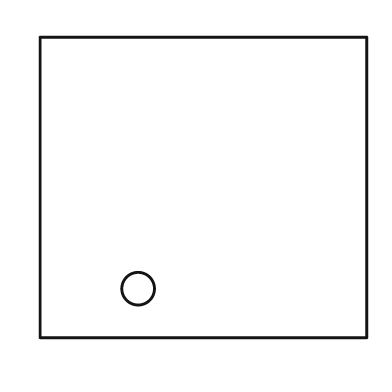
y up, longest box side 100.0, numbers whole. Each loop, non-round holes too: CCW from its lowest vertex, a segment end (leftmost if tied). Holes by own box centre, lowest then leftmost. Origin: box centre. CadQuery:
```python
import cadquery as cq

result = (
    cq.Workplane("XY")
    .moveTo(-50.0, -46.0)
    .lineTo(50.0, -46.0)
    .lineTo(50.0, 46.0)
    .lineTo(-50.0, 46.0)
    .close()
    .moveTo(-20.0, -31.0)
    .circle(5.0)
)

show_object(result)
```